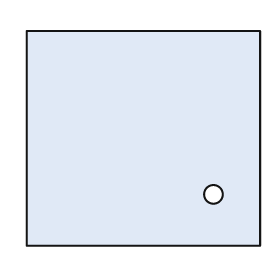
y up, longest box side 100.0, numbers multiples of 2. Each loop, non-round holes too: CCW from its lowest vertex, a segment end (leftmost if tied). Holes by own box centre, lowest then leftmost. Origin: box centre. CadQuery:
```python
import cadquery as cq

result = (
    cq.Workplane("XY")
    .moveTo(-50.0, -46.0)
    .lineTo(50.0, -46.0)
    .lineTo(50.0, 46.0)
    .lineTo(-50.0, 46.0)
    .close()
    .moveTo(30.0, -24.0)
    .circle(4.0)
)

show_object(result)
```